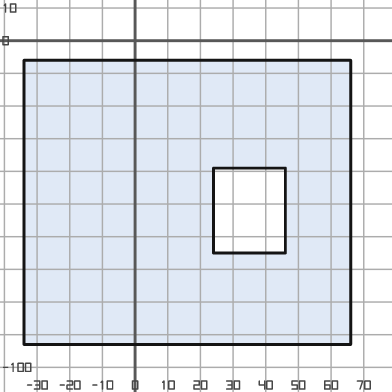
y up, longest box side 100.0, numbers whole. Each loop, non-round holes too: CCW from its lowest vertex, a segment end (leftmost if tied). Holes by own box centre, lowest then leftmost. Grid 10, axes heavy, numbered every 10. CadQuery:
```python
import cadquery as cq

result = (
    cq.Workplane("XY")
    .moveTo(-34.0, -93.0)
    .lineTo(66.0, -93.0)
    .lineTo(66.0, -6.0)
    .lineTo(-34.0, -6.0)
    .close()
    .moveTo(24.0, -65.0)
    .lineTo(46.0, -65.0)
    .lineTo(46.0, -39.0)
    .lineTo(24.0, -39.0)
    .close()
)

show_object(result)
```